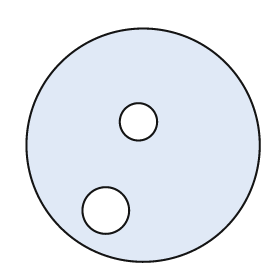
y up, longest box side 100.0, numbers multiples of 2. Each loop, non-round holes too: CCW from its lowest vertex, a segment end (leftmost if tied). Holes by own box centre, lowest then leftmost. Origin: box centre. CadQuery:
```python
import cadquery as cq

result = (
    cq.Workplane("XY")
    .moveTo(0.0, 0.0)
    .circle(50.0)
    .moveTo(-16.0, -28.0)
    .circle(10.0)
    .moveTo(-2.0, 10.0)
    .circle(8.0)
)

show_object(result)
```